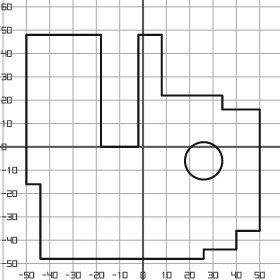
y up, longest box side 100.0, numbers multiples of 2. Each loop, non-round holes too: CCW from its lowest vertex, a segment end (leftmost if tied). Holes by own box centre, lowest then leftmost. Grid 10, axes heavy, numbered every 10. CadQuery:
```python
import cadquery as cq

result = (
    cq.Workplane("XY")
    .moveTo(-44.0, -48.0)
    .lineTo(26.0, -48.0)
    .lineTo(26.0, -44.0)
    .lineTo(40.0, -44.0)
    .lineTo(40.0, -36.0)
    .lineTo(50.0, -36.0)
    .lineTo(50.0, 16.0)
    .lineTo(34.0, 16.0)
    .lineTo(34.0, 22.0)
    .lineTo(8.0, 22.0)
    .lineTo(8.0, 48.0)
    .lineTo(-2.0, 48.0)
    .lineTo(-2.0, 0.0)
    .lineTo(-18.0, 0.0)
    .lineTo(-18.0, 48.0)
    .lineTo(-50.0, 48.0)
    .lineTo(-50.0, -16.0)
    .lineTo(-44.0, -16.0)
    .close()
    .moveTo(26.0, -6.0)
    .circle(8.0)
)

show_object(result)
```